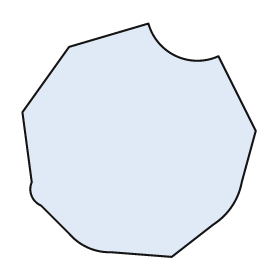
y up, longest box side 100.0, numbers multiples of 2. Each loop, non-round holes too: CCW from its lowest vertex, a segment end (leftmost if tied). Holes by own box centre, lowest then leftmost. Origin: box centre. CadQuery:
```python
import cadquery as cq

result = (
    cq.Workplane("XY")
    .moveTo(14.0, -50.0)
    .lineTo(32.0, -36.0)
    .threePointArc((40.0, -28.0), (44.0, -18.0))
    .lineTo(50.0, 4.0)
    .lineTo(34.0, 36.0)
    .threePointArc((16.0, 36.0), (4.0, 50.0))
    .lineTo(-30.0, 40.0)
    .lineTo(-50.0, 12.0)
    .lineTo(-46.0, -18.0)
    .threePointArc((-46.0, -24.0), (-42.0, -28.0))
    .lineTo(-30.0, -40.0)
    .threePointArc((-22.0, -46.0), (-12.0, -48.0))
    .close()
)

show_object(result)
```